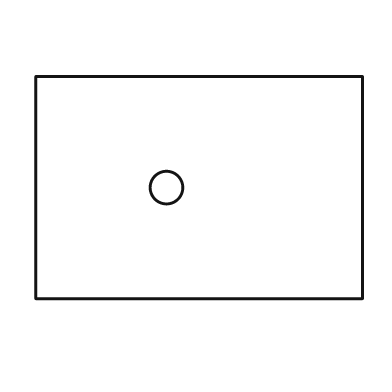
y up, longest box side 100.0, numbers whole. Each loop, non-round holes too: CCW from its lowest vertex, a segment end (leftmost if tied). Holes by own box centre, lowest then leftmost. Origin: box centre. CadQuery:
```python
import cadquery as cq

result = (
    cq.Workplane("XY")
    .moveTo(-50.0, -34.0)
    .lineTo(50.0, -34.0)
    .lineTo(50.0, 34.0)
    .lineTo(-50.0, 34.0)
    .close()
    .moveTo(-10.0, 0.0)
    .circle(5.0)
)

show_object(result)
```